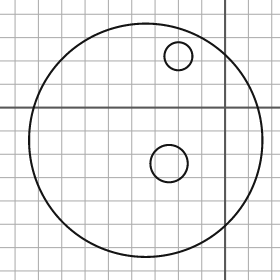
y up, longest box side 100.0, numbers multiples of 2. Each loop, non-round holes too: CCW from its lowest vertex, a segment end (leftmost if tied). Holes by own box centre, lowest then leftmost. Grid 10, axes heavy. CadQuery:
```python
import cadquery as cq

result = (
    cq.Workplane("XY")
    .moveTo(-34.0, -14.0)
    .circle(50.0)
    .moveTo(-24.0, -24.0)
    .circle(8.0)
    .moveTo(-20.0, 22.0)
    .circle(6.0)
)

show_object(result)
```